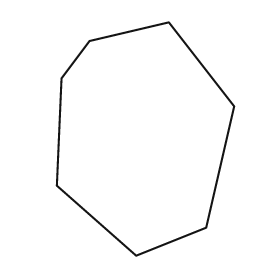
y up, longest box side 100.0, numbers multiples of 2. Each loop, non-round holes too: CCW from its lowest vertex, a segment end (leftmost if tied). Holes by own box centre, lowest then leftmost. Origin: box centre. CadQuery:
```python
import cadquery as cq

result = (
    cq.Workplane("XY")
    .moveTo(-4.0, -50.0)
    .lineTo(26.0, -38.0)
    .lineTo(38.0, 14.0)
    .lineTo(10.0, 50.0)
    .lineTo(-24.0, 42.0)
    .lineTo(-36.0, 26.0)
    .lineTo(-38.0, -20.0)
    .close()
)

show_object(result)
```